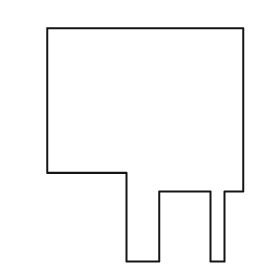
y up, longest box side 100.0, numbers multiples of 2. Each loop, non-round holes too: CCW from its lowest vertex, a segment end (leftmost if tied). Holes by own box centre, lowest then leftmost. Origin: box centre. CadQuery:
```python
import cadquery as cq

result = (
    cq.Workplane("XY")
    .moveTo(-8.0, -50.0)
    .lineTo(6.0, -50.0)
    .lineTo(6.0, -20.0)
    .lineTo(28.0, -20.0)
    .lineTo(28.0, -50.0)
    .lineTo(34.0, -50.0)
    .lineTo(34.0, -20.0)
    .lineTo(42.0, -20.0)
    .lineTo(42.0, 50.0)
    .lineTo(-42.0, 50.0)
    .lineTo(-42.0, -12.0)
    .lineTo(-8.0, -12.0)
    .close()
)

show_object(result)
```